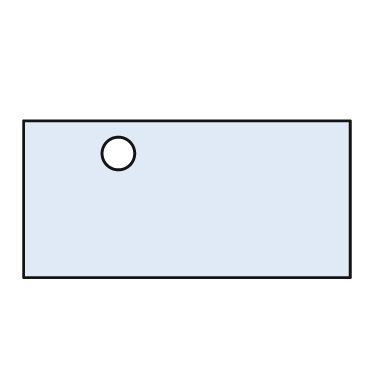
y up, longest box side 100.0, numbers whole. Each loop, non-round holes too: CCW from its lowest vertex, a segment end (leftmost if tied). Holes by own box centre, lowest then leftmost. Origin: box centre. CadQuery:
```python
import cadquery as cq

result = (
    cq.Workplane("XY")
    .moveTo(-50.0, -24.0)
    .lineTo(50.0, -24.0)
    .lineTo(50.0, 24.0)
    .lineTo(-50.0, 24.0)
    .close()
    .moveTo(-21.0, 14.0)
    .circle(5.0)
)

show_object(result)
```